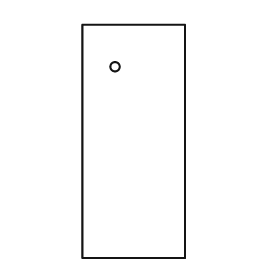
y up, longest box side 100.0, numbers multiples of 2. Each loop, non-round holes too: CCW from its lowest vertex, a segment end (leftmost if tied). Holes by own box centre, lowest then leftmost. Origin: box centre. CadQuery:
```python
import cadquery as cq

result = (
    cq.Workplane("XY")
    .moveTo(-22.0, -50.0)
    .lineTo(22.0, -50.0)
    .lineTo(22.0, 50.0)
    .lineTo(-22.0, 50.0)
    .close()
    .moveTo(-8.0, 32.0)
    .circle(2.0)
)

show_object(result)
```